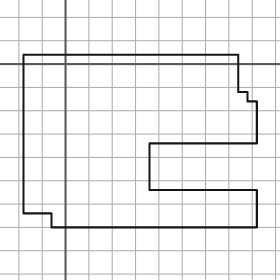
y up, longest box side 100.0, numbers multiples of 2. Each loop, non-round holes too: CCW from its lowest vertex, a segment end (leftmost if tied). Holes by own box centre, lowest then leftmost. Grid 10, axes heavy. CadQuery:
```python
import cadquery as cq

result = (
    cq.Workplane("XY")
    .moveTo(-6.0, -70.0)
    .lineTo(82.0, -70.0)
    .lineTo(82.0, -54.0)
    .lineTo(36.0, -54.0)
    .lineTo(36.0, -34.0)
    .lineTo(82.0, -34.0)
    .lineTo(82.0, -16.0)
    .lineTo(78.0, -16.0)
    .lineTo(78.0, -12.0)
    .lineTo(74.0, -12.0)
    .lineTo(74.0, 4.0)
    .lineTo(-18.0, 4.0)
    .lineTo(-18.0, -64.0)
    .lineTo(-6.0, -64.0)
    .close()
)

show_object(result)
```